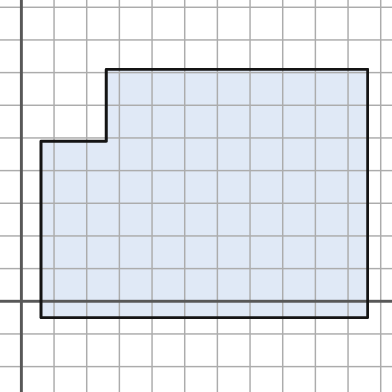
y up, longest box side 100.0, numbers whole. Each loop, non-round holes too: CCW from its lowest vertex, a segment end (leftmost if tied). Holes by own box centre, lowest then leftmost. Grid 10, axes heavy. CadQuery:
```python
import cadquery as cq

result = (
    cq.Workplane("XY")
    .moveTo(6.0, -5.0)
    .lineTo(106.0, -5.0)
    .lineTo(106.0, 71.0)
    .lineTo(26.0, 71.0)
    .lineTo(26.0, 49.0)
    .lineTo(6.0, 49.0)
    .close()
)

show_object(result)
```